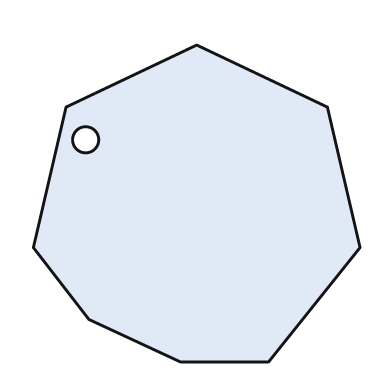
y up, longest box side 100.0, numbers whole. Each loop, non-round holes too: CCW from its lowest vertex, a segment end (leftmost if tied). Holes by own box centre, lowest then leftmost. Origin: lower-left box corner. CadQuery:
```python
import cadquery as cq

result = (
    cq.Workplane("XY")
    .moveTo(45.0, 0.0)
    .lineTo(72.0, 0.0)
    .lineTo(100.0, 35.0)
    .lineTo(90.0, 78.0)
    .lineTo(50.0, 97.0)
    .lineTo(10.0, 78.0)
    .lineTo(0.0, 35.0)
    .lineTo(17.0, 13.0)
    .close()
    .moveTo(16.0, 68.0)
    .circle(4.0)
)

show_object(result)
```